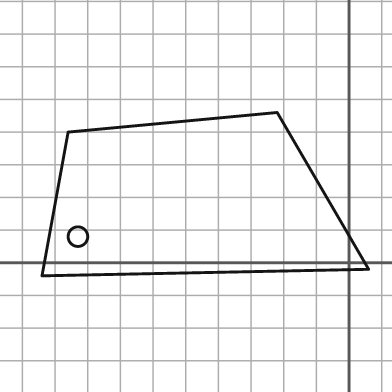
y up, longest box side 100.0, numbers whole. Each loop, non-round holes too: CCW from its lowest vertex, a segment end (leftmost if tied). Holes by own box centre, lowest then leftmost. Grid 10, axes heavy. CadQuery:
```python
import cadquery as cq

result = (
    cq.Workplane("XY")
    .moveTo(-94.0, -4.0)
    .lineTo(6.0, -2.0)
    .lineTo(-22.0, 46.0)
    .lineTo(-86.0, 40.0)
    .close()
    .moveTo(-83.0, 8.0)
    .circle(3.0)
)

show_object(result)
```